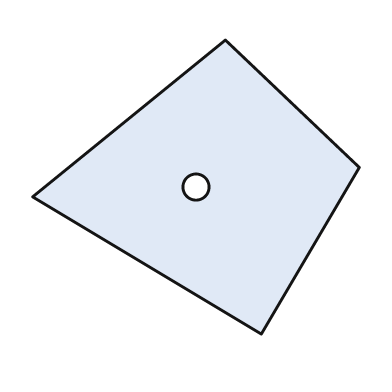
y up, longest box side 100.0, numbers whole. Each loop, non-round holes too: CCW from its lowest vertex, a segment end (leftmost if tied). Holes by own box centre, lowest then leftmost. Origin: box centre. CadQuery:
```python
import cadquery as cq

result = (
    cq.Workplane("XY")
    .moveTo(20.0, -45.0)
    .lineTo(50.0, 6.0)
    .lineTo(9.0, 45.0)
    .lineTo(-50.0, -3.0)
    .close()
    .moveTo(0.0, 0.0)
    .circle(4.0)
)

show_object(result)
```